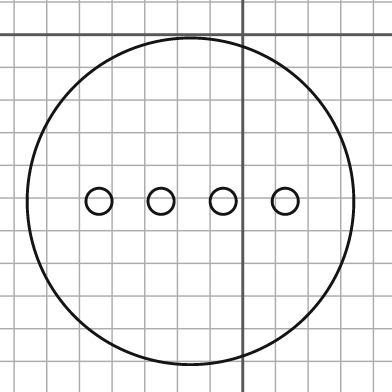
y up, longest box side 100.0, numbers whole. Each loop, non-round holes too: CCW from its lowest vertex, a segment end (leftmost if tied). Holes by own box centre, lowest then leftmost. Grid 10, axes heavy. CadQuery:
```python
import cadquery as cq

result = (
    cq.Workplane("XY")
    .moveTo(-16.0, -51.0)
    .circle(50.0)
    .moveTo(-44.0, -51.0)
    .circle(4.0)
    .moveTo(-25.0, -51.0)
    .circle(4.0)
    .moveTo(-6.0, -51.0)
    .circle(4.0)
    .moveTo(13.0, -51.0)
    .circle(4.0)
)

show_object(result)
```